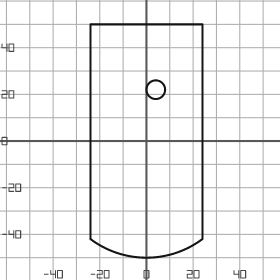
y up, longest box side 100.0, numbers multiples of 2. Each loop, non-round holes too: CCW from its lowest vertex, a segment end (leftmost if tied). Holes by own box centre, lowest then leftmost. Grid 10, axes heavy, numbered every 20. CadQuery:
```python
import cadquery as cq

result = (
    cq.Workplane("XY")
    .moveTo(-24.0, -42.0)
    .threePointArc((0.0, -50.0), (24.0, -42.0))
    .lineTo(24.0, 50.0)
    .lineTo(-24.0, 50.0)
    .close()
    .moveTo(4.0, 22.0)
    .circle(4.0)
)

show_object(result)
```